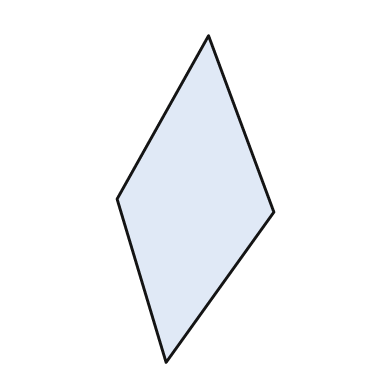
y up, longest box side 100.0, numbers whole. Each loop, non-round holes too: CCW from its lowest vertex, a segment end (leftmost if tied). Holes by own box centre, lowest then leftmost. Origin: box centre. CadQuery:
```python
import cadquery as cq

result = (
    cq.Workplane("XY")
    .moveTo(-9.0, -50.0)
    .lineTo(24.0, -4.0)
    .lineTo(4.0, 50.0)
    .lineTo(-24.0, 0.0)
    .close()
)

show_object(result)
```